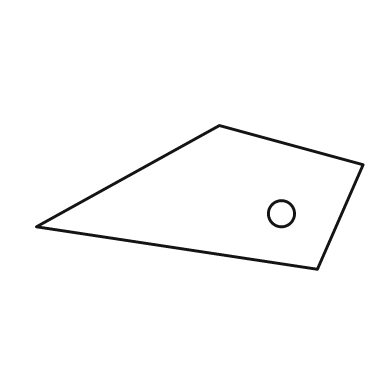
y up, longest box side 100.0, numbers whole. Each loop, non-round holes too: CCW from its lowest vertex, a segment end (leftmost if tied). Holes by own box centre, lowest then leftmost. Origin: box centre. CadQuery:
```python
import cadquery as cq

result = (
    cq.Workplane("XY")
    .moveTo(36.0, -22.0)
    .lineTo(50.0, 10.0)
    .lineTo(6.0, 22.0)
    .lineTo(-50.0, -9.0)
    .close()
    .moveTo(25.0, -5.0)
    .circle(4.0)
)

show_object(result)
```